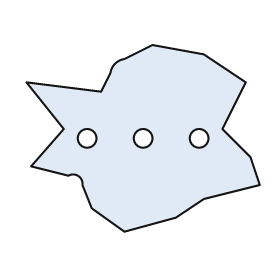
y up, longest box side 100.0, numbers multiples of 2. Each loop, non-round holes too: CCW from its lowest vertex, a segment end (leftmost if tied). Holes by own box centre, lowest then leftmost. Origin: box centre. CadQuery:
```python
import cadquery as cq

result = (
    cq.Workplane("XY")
    .moveTo(-8.0, -40.0)
    .lineTo(14.0, -34.0)
    .lineTo(26.0, -26.0)
    .lineTo(50.0, -20.0)
    .lineTo(46.0, -8.0)
    .lineTo(34.0, 4.0)
    .lineTo(44.0, 24.0)
    .lineTo(26.0, 36.0)
    .lineTo(4.0, 40.0)
    .lineTo(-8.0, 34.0)
    .threePointArc((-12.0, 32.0), (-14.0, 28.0))
    .lineTo(-18.0, 20.0)
    .lineTo(-50.0, 24.0)
    .lineTo(-34.0, 4.0)
    .lineTo(-48.0, -12.0)
    .lineTo(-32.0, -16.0)
    .threePointArc((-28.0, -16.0), (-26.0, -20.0))
    .lineTo(-22.0, -30.0)
    .close()
    .moveTo(-24.0, 0.0)
    .circle(4.0)
    .moveTo(0.0, 0.0)
    .circle(4.0)
    .moveTo(24.0, 0.0)
    .circle(4.0)
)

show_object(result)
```